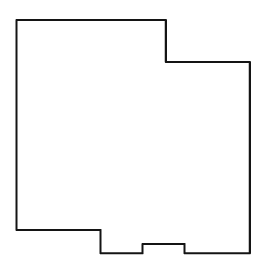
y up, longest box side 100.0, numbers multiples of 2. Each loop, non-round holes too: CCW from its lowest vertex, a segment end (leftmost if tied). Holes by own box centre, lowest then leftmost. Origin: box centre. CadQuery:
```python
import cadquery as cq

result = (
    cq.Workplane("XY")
    .moveTo(-14.0, -50.0)
    .lineTo(4.0, -50.0)
    .lineTo(4.0, -46.0)
    .lineTo(22.0, -46.0)
    .lineTo(22.0, -50.0)
    .lineTo(50.0, -50.0)
    .lineTo(50.0, 32.0)
    .lineTo(14.0, 32.0)
    .lineTo(14.0, 50.0)
    .lineTo(-50.0, 50.0)
    .lineTo(-50.0, -40.0)
    .lineTo(-14.0, -40.0)
    .close()
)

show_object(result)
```